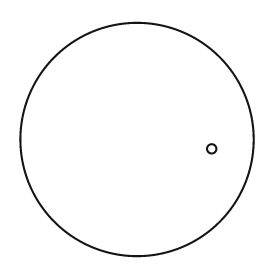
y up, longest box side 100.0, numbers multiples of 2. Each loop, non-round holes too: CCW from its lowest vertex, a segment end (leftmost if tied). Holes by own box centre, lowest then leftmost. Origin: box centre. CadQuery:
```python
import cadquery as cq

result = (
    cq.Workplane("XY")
    .moveTo(0.0, 0.0)
    .circle(50.0)
    .moveTo(32.0, -4.0)
    .circle(2.0)
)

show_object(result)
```